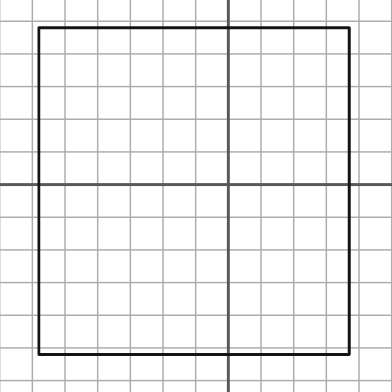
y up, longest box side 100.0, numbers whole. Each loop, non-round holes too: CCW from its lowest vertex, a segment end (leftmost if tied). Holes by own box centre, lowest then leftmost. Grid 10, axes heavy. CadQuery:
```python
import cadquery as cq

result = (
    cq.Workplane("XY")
    .moveTo(-58.0, -52.0)
    .lineTo(37.0, -52.0)
    .lineTo(37.0, 48.0)
    .lineTo(-58.0, 48.0)
    .close()
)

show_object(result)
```